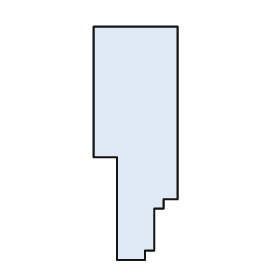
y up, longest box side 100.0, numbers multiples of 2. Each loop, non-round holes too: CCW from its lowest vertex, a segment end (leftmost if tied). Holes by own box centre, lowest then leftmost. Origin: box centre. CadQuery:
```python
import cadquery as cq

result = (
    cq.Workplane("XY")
    .moveTo(-8.0, -50.0)
    .lineTo(4.0, -50.0)
    .lineTo(4.0, -46.0)
    .lineTo(8.0, -46.0)
    .lineTo(8.0, -28.0)
    .lineTo(12.0, -28.0)
    .lineTo(12.0, -24.0)
    .lineTo(18.0, -24.0)
    .lineTo(18.0, 50.0)
    .lineTo(-18.0, 50.0)
    .lineTo(-18.0, -6.0)
    .lineTo(-8.0, -6.0)
    .close()
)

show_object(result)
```